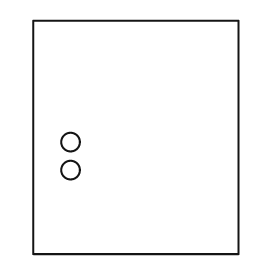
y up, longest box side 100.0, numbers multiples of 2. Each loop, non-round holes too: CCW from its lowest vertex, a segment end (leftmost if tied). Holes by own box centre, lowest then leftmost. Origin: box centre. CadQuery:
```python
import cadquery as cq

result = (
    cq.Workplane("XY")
    .moveTo(-44.0, -50.0)
    .lineTo(44.0, -50.0)
    .lineTo(44.0, 50.0)
    .lineTo(-44.0, 50.0)
    .close()
    .moveTo(-28.0, -14.0)
    .circle(4.0)
    .moveTo(-28.0, -2.0)
    .circle(4.0)
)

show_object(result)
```